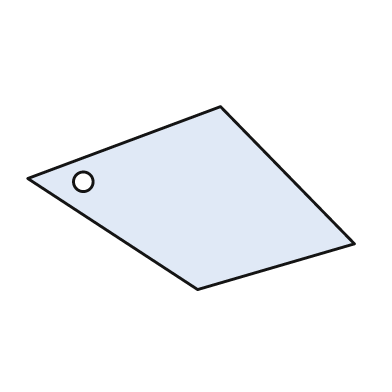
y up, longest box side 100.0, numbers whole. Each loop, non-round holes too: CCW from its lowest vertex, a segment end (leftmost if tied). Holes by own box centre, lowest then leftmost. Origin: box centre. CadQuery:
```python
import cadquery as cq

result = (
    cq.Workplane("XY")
    .moveTo(2.0, -28.0)
    .lineTo(50.0, -14.0)
    .lineTo(9.0, 28.0)
    .lineTo(-50.0, 6.0)
    .close()
    .moveTo(-33.0, 5.0)
    .circle(3.0)
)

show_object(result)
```